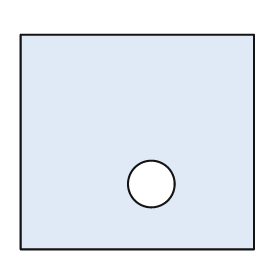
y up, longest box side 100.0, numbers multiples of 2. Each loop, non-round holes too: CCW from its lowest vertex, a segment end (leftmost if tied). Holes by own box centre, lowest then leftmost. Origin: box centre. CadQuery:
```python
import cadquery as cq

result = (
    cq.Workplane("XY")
    .moveTo(-50.0, -46.0)
    .lineTo(50.0, -46.0)
    .lineTo(50.0, 46.0)
    .lineTo(-50.0, 46.0)
    .close()
    .moveTo(6.0, -18.0)
    .circle(10.0)
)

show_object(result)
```